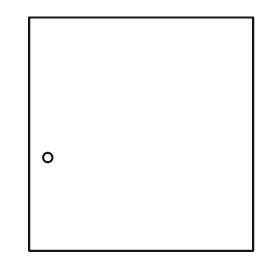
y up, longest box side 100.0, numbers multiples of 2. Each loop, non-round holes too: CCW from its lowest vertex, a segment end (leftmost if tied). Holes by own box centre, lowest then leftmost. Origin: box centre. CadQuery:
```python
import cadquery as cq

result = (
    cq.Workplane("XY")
    .moveTo(-48.0, -50.0)
    .lineTo(48.0, -50.0)
    .lineTo(48.0, 50.0)
    .lineTo(-48.0, 50.0)
    .close()
    .moveTo(-40.0, -10.0)
    .circle(2.0)
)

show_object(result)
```